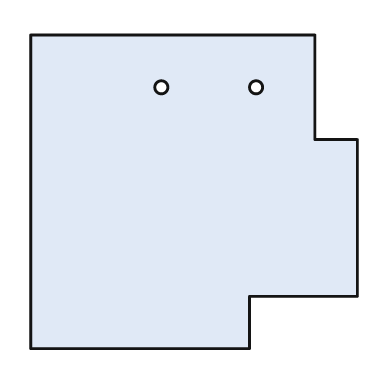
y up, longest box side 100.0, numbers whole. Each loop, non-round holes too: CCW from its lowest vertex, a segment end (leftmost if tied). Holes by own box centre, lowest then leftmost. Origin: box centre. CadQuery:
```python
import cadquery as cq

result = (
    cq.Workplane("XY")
    .moveTo(-50.0, -48.0)
    .lineTo(17.0, -48.0)
    .lineTo(17.0, -32.0)
    .lineTo(50.0, -32.0)
    .lineTo(50.0, 16.0)
    .lineTo(37.0, 16.0)
    .lineTo(37.0, 48.0)
    .lineTo(-50.0, 48.0)
    .close()
    .moveTo(-10.0, 32.0)
    .circle(2.0)
    .moveTo(19.0, 32.0)
    .circle(2.0)
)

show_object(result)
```